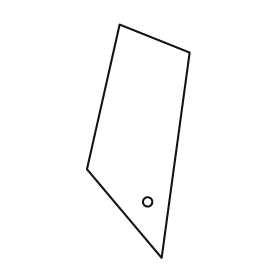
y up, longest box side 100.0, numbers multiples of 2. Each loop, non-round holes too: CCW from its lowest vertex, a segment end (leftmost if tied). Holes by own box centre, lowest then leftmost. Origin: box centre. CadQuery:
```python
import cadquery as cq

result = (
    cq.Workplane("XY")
    .moveTo(10.0, -50.0)
    .lineTo(22.0, 38.0)
    .lineTo(-8.0, 50.0)
    .lineTo(-22.0, -12.0)
    .close()
    .moveTo(4.0, -26.0)
    .circle(2.0)
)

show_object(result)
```